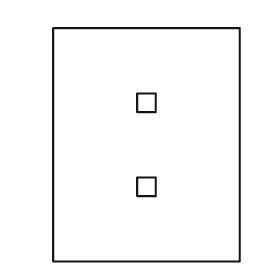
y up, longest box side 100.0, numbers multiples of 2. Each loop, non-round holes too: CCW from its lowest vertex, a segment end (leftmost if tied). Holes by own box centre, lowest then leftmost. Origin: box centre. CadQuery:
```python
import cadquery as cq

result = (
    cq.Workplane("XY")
    .moveTo(-40.0, -50.0)
    .lineTo(40.0, -50.0)
    .lineTo(40.0, 50.0)
    .lineTo(-40.0, 50.0)
    .close()
    .moveTo(-4.0, -22.0)
    .lineTo(4.0, -22.0)
    .lineTo(4.0, -14.0)
    .lineTo(-4.0, -14.0)
    .close()
    .moveTo(-4.0, 14.0)
    .lineTo(4.0, 14.0)
    .lineTo(4.0, 22.0)
    .lineTo(-4.0, 22.0)
    .close()
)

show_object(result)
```